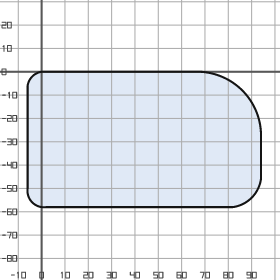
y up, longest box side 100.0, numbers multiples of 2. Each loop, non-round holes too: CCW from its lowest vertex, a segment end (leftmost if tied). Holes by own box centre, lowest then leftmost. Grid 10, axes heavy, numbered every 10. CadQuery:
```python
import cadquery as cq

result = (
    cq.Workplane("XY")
    .moveTo(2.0, -58.0)
    .lineTo(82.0, -58.0)
    .threePointArc((90.0, -54.0), (94.0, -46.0))
    .lineTo(94.0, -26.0)
    .threePointArc((86.0, -8.0), (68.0, 0.0))
    .lineTo(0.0, 0.0)
    .threePointArc((-4.0, -2.0), (-6.0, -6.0))
    .lineTo(-6.0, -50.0)
    .threePointArc((-4.0, -56.0), (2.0, -58.0))
    .close()
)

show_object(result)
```